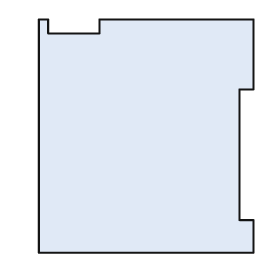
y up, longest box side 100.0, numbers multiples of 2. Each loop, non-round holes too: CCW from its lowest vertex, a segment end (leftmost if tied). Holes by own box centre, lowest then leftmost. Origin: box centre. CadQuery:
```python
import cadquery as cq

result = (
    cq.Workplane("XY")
    .moveTo(-46.0, -50.0)
    .lineTo(46.0, -50.0)
    .lineTo(46.0, -36.0)
    .lineTo(40.0, -36.0)
    .lineTo(40.0, 20.0)
    .lineTo(46.0, 20.0)
    .lineTo(46.0, 50.0)
    .lineTo(-20.0, 50.0)
    .lineTo(-20.0, 44.0)
    .lineTo(-42.0, 44.0)
    .lineTo(-42.0, 50.0)
    .lineTo(-46.0, 50.0)
    .close()
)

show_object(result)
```